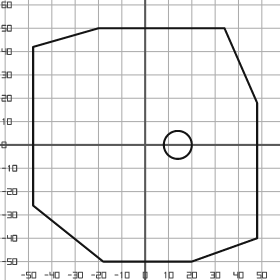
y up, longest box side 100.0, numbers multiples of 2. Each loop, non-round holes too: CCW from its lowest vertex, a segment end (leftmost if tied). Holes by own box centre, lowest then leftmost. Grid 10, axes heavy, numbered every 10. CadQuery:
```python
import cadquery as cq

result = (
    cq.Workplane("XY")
    .moveTo(-18.0, -50.0)
    .lineTo(20.0, -50.0)
    .lineTo(48.0, -40.0)
    .lineTo(48.0, 18.0)
    .lineTo(34.0, 50.0)
    .lineTo(-20.0, 50.0)
    .lineTo(-48.0, 42.0)
    .lineTo(-48.0, -26.0)
    .close()
    .moveTo(14.0, 0.0)
    .circle(6.0)
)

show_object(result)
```